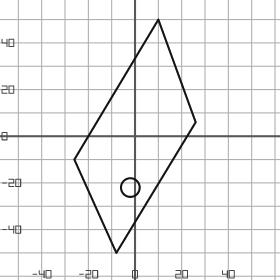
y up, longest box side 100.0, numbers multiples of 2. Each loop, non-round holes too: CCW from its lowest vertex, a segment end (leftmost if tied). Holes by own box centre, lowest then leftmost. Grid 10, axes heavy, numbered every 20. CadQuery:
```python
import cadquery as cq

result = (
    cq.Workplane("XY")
    .moveTo(-8.0, -50.0)
    .lineTo(26.0, 6.0)
    .lineTo(10.0, 50.0)
    .lineTo(-26.0, -10.0)
    .close()
    .moveTo(-2.0, -22.0)
    .circle(4.0)
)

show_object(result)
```